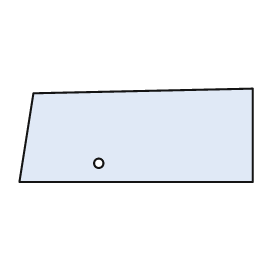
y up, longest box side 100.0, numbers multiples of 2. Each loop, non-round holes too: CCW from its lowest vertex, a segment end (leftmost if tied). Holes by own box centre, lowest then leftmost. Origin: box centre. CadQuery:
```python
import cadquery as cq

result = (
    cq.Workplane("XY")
    .moveTo(-50.0, -20.0)
    .lineTo(50.0, -20.0)
    .lineTo(50.0, 20.0)
    .lineTo(-44.0, 18.0)
    .close()
    .moveTo(-16.0, -12.0)
    .circle(2.0)
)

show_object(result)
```